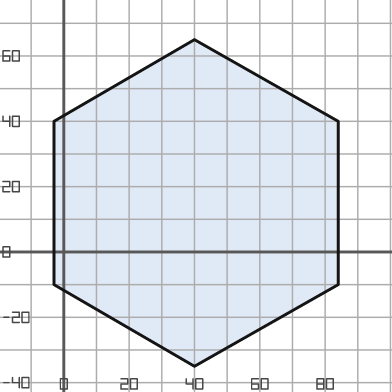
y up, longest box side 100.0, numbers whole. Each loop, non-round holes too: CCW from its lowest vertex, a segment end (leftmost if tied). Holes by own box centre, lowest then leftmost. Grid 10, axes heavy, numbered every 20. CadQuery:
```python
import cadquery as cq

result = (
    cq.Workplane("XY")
    .moveTo(40.0, -35.0)
    .lineTo(84.0, -10.0)
    .lineTo(84.0, 40.0)
    .lineTo(40.0, 65.0)
    .lineTo(-3.0, 40.0)
    .lineTo(-3.0, -10.0)
    .close()
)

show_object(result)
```